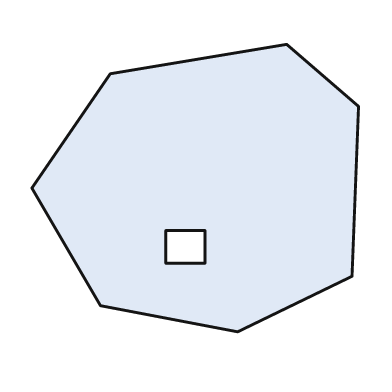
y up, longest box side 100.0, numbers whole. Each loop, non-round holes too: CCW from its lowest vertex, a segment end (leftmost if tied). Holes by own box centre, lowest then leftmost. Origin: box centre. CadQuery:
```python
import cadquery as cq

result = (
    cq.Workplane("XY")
    .moveTo(13.0, -44.0)
    .lineTo(48.0, -27.0)
    .lineTo(50.0, 25.0)
    .lineTo(28.0, 44.0)
    .lineTo(-26.0, 35.0)
    .lineTo(-50.0, 0.0)
    .lineTo(-29.0, -36.0)
    .close()
    .moveTo(-9.0, -23.0)
    .lineTo(3.0, -23.0)
    .lineTo(3.0, -13.0)
    .lineTo(-9.0, -13.0)
    .close()
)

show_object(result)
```